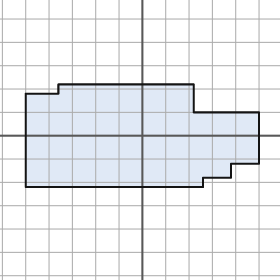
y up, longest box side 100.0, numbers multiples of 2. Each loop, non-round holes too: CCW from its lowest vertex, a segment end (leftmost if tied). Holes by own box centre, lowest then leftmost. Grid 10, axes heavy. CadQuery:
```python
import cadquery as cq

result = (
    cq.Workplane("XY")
    .moveTo(-50.0, -22.0)
    .lineTo(26.0, -22.0)
    .lineTo(26.0, -18.0)
    .lineTo(38.0, -18.0)
    .lineTo(38.0, -12.0)
    .lineTo(50.0, -12.0)
    .lineTo(50.0, 10.0)
    .lineTo(22.0, 10.0)
    .lineTo(22.0, 22.0)
    .lineTo(-36.0, 22.0)
    .lineTo(-36.0, 18.0)
    .lineTo(-50.0, 18.0)
    .close()
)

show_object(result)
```